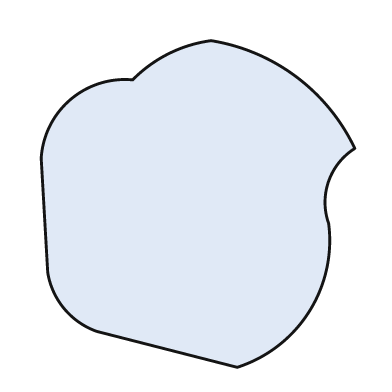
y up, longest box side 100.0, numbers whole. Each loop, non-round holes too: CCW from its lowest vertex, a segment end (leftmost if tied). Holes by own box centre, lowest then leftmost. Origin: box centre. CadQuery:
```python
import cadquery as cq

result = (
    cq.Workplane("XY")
    .moveTo(12.0, -50.0)
    .threePointArc((34.0, -33.0), (40.0, -6.0))
    .threePointArc((40.0, 7.0), (48.0, 17.0))
    .threePointArc((30.0, 39.0), (4.0, 50.0))
    .threePointArc((-9.0, 46.0), (-20.0, 38.0))
    .threePointArc((-39.0, 32.0), (-48.0, 14.0))
    .lineTo(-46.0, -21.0)
    .threePointArc((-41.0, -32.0), (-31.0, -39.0))
    .close()
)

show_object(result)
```